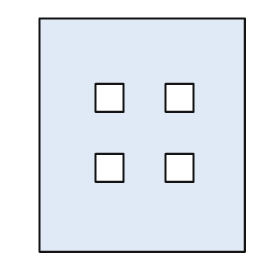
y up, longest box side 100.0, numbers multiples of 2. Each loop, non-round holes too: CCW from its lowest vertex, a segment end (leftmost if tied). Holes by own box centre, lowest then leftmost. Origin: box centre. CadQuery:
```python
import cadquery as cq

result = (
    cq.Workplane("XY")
    .moveTo(-44.0, -50.0)
    .lineTo(44.0, -50.0)
    .lineTo(44.0, 50.0)
    .lineTo(-44.0, 50.0)
    .close()
    .moveTo(-20.0, -20.0)
    .lineTo(-8.0, -20.0)
    .lineTo(-8.0, -8.0)
    .lineTo(-20.0, -8.0)
    .close()
    .moveTo(10.0, -20.0)
    .lineTo(22.0, -20.0)
    .lineTo(22.0, -8.0)
    .lineTo(10.0, -8.0)
    .close()
    .moveTo(-20.0, 10.0)
    .lineTo(-8.0, 10.0)
    .lineTo(-8.0, 22.0)
    .lineTo(-20.0, 22.0)
    .close()
    .moveTo(10.0, 10.0)
    .lineTo(22.0, 10.0)
    .lineTo(22.0, 22.0)
    .lineTo(10.0, 22.0)
    .close()
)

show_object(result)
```